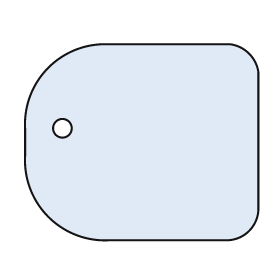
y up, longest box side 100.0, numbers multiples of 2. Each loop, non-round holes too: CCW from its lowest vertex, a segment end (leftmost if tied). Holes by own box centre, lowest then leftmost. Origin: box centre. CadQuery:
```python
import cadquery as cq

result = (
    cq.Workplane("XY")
    .moveTo(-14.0, -42.0)
    .lineTo(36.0, -42.0)
    .threePointArc((46.0, -38.0), (50.0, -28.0))
    .lineTo(50.0, 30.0)
    .threePointArc((46.0, 38.0), (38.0, 42.0))
    .lineTo(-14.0, 42.0)
    .threePointArc((-40.0, 32.0), (-50.0, 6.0))
    .lineTo(-50.0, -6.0)
    .threePointArc((-40.0, -32.0), (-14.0, -42.0))
    .close()
    .moveTo(-34.0, 6.0)
    .circle(4.0)
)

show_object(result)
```